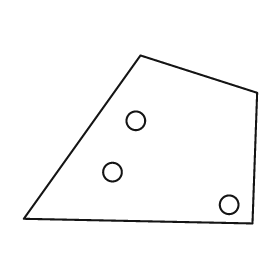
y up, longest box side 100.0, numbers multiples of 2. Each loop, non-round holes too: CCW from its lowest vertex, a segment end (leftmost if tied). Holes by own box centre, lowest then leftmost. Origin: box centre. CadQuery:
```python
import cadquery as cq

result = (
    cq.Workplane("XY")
    .moveTo(48.0, -36.0)
    .lineTo(50.0, 20.0)
    .lineTo(0.0, 36.0)
    .lineTo(-50.0, -34.0)
    .close()
    .moveTo(38.0, -28.0)
    .circle(4.0)
    .moveTo(-12.0, -14.0)
    .circle(4.0)
    .moveTo(-2.0, 8.0)
    .circle(4.0)
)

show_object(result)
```